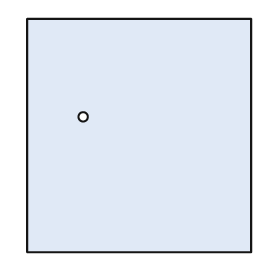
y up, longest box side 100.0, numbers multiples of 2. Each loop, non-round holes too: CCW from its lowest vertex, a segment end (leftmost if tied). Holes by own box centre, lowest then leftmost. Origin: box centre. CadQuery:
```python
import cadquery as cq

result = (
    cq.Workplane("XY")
    .moveTo(-48.0, -50.0)
    .lineTo(48.0, -50.0)
    .lineTo(48.0, 50.0)
    .lineTo(-48.0, 50.0)
    .close()
    .moveTo(-24.0, 8.0)
    .circle(2.0)
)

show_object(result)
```